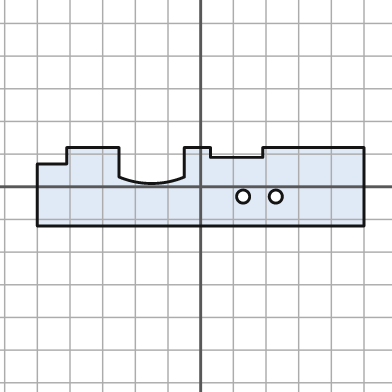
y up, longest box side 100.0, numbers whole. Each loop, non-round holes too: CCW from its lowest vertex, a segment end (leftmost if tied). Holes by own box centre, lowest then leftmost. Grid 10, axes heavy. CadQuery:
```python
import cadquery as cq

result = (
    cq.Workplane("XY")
    .moveTo(-50.0, -12.0)
    .lineTo(50.0, -12.0)
    .lineTo(50.0, 12.0)
    .lineTo(19.0, 12.0)
    .lineTo(19.0, 9.0)
    .lineTo(3.0, 9.0)
    .lineTo(3.0, 12.0)
    .lineTo(-5.0, 12.0)
    .lineTo(-5.0, 3.0)
    .threePointArc((-15.0, 1.0), (-25.0, 3.0))
    .lineTo(-25.0, 12.0)
    .lineTo(-41.0, 12.0)
    .lineTo(-41.0, 7.0)
    .lineTo(-50.0, 7.0)
    .close()
    .moveTo(13.0, -3.0)
    .circle(2.0)
    .moveTo(23.0, -3.0)
    .circle(2.0)
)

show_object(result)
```